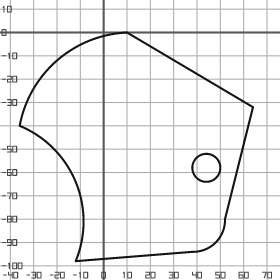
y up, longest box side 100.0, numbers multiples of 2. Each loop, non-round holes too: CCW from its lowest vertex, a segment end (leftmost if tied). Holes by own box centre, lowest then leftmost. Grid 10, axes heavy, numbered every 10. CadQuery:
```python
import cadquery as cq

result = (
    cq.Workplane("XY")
    .moveTo(-12.0, -98.0)
    .lineTo(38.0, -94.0)
    .threePointArc((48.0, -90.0), (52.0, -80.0))
    .lineTo(64.0, -32.0)
    .lineTo(10.0, 0.0)
    .threePointArc((-20.0, -12.0), (-36.0, -40.0))
    .threePointArc((-12.0, -64.0), (-12.0, -98.0))
    .close()
    .moveTo(44.0, -58.0)
    .circle(6.0)
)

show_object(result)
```